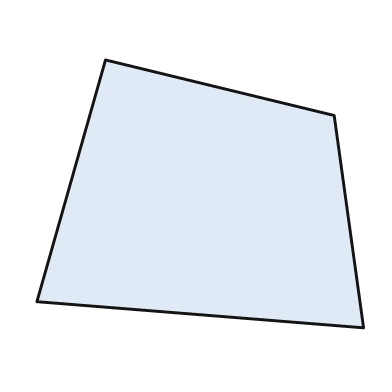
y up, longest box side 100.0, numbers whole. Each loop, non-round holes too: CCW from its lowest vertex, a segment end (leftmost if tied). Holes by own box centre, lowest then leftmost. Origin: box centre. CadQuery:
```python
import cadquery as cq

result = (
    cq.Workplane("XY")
    .moveTo(50.0, -41.0)
    .lineTo(41.0, 24.0)
    .lineTo(-29.0, 41.0)
    .lineTo(-50.0, -33.0)
    .close()
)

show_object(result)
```